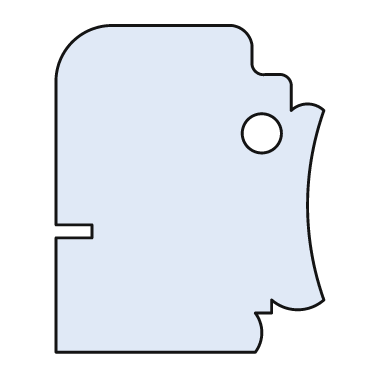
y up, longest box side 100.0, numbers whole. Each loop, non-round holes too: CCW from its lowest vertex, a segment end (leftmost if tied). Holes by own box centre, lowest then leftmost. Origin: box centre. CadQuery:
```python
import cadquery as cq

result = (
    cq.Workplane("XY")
    .moveTo(-41.0, -50.0)
    .lineTo(20.0, -50.0)
    .threePointArc((22.0, -44.0), (20.0, -38.0))
    .lineTo(25.0, -38.0)
    .lineTo(25.0, -34.0)
    .threePointArc((33.0, -37.0), (41.0, -34.0))
    .threePointArc((36.0, -5.0), (41.0, 24.0))
    .threePointArc((36.0, 26.0), (31.0, 24.0))
    .lineTo(31.0, 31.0)
    .threePointArc((30.0, 34.0), (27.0, 35.0))
    .lineTo(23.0, 35.0)
    .threePointArc((20.0, 36.0), (19.0, 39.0))
    .lineTo(19.0, 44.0)
    .threePointArc((17.0, 48.0), (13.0, 50.0))
    .lineTo(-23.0, 50.0)
    .threePointArc((-36.0, 45.0), (-41.0, 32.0))
    .lineTo(-41.0, -11.0)
    .lineTo(-30.0, -11.0)
    .lineTo(-30.0, -15.0)
    .lineTo(-41.0, -15.0)
    .close()
    .moveTo(22.0, 17.0)
    .circle(6.0)
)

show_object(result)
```